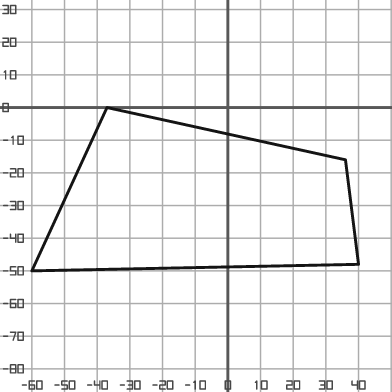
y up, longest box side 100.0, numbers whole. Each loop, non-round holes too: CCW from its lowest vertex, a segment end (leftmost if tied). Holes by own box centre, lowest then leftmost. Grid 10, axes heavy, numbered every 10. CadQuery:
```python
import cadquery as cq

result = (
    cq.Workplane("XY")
    .moveTo(-60.0, -50.0)
    .lineTo(40.0, -48.0)
    .lineTo(36.0, -16.0)
    .lineTo(-37.0, 0.0)
    .close()
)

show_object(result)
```